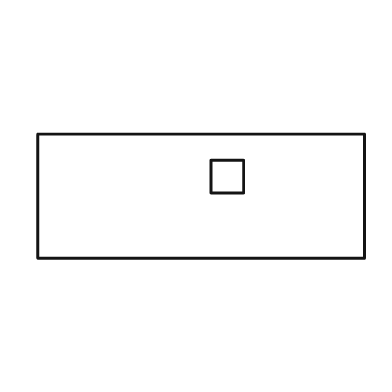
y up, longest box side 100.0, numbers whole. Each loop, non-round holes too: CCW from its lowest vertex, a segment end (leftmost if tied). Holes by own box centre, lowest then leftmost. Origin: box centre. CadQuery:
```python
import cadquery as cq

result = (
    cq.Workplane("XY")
    .moveTo(-50.0, -19.0)
    .lineTo(50.0, -19.0)
    .lineTo(50.0, 19.0)
    .lineTo(-50.0, 19.0)
    .close()
    .moveTo(3.0, 1.0)
    .lineTo(13.0, 1.0)
    .lineTo(13.0, 11.0)
    .lineTo(3.0, 11.0)
    .close()
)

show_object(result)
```